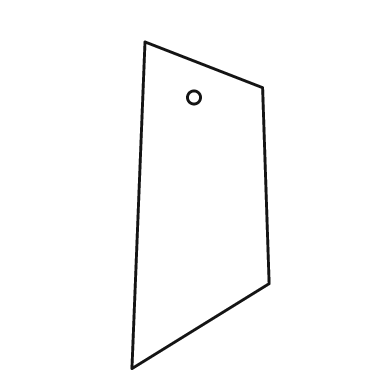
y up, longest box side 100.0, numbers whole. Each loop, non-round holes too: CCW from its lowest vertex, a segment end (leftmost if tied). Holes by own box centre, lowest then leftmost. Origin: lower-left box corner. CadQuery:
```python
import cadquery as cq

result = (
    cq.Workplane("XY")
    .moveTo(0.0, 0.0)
    .lineTo(42.0, 26.0)
    .lineTo(40.0, 86.0)
    .lineTo(4.0, 100.0)
    .close()
    .moveTo(19.0, 83.0)
    .circle(2.0)
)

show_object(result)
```